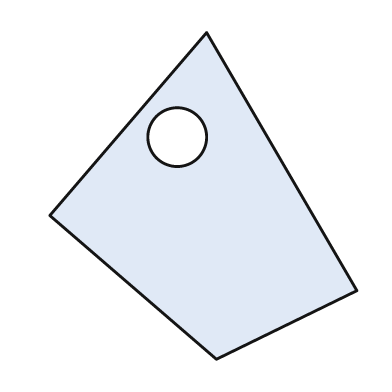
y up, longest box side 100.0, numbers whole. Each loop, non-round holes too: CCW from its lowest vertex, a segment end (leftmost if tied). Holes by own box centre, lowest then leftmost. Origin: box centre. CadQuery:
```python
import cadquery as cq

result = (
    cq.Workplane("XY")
    .moveTo(4.0, -50.0)
    .lineTo(47.0, -29.0)
    .lineTo(1.0, 50.0)
    .lineTo(-47.0, -6.0)
    .close()
    .moveTo(-8.0, 18.0)
    .circle(9.0)
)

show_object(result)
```